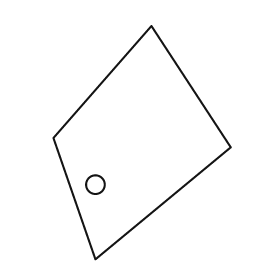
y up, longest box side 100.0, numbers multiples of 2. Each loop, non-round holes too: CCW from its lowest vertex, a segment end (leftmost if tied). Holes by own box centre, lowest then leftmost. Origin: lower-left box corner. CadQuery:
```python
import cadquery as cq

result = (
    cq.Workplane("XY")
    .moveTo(18.0, 0.0)
    .lineTo(76.0, 48.0)
    .lineTo(42.0, 100.0)
    .lineTo(0.0, 52.0)
    .close()
    .moveTo(18.0, 32.0)
    .circle(4.0)
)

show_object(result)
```